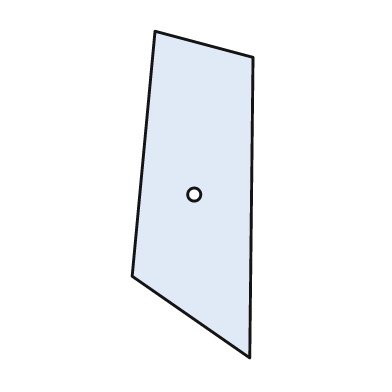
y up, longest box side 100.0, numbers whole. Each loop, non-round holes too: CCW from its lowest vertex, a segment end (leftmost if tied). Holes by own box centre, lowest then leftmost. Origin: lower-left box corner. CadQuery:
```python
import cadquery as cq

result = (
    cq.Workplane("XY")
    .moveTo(36.0, 0.0)
    .lineTo(37.0, 92.0)
    .lineTo(7.0, 100.0)
    .lineTo(0.0, 25.0)
    .close()
    .moveTo(19.0, 50.0)
    .circle(2.0)
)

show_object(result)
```